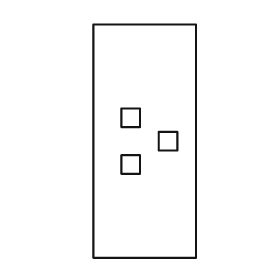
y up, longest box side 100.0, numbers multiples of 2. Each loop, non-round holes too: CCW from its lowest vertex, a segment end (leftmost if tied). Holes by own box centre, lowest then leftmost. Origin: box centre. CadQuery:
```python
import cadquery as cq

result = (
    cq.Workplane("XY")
    .moveTo(-22.0, -50.0)
    .lineTo(22.0, -50.0)
    .lineTo(22.0, 50.0)
    .lineTo(-22.0, 50.0)
    .close()
    .moveTo(-10.0, -14.0)
    .lineTo(-2.0, -14.0)
    .lineTo(-2.0, -6.0)
    .lineTo(-10.0, -6.0)
    .close()
    .moveTo(6.0, -4.0)
    .lineTo(14.0, -4.0)
    .lineTo(14.0, 4.0)
    .lineTo(6.0, 4.0)
    .close()
    .moveTo(-10.0, 6.0)
    .lineTo(-2.0, 6.0)
    .lineTo(-2.0, 14.0)
    .lineTo(-10.0, 14.0)
    .close()
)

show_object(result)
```